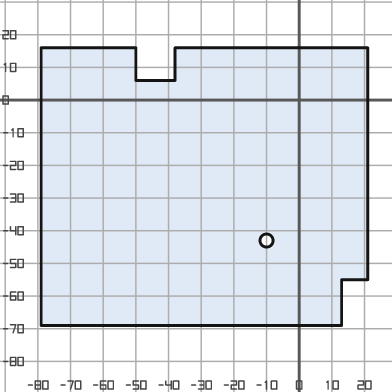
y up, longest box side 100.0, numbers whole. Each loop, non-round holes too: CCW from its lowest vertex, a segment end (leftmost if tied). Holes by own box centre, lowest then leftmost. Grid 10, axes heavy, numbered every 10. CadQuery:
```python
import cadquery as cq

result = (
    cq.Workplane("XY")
    .moveTo(-79.0, -69.0)
    .lineTo(13.0, -69.0)
    .lineTo(13.0, -55.0)
    .lineTo(21.0, -55.0)
    .lineTo(21.0, 16.0)
    .lineTo(-38.0, 16.0)
    .lineTo(-38.0, 6.0)
    .lineTo(-50.0, 6.0)
    .lineTo(-50.0, 16.0)
    .lineTo(-79.0, 16.0)
    .close()
    .moveTo(-10.0, -43.0)
    .circle(2.0)
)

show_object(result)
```